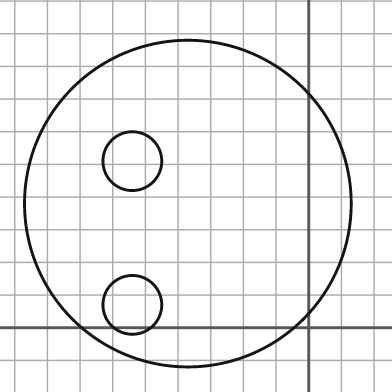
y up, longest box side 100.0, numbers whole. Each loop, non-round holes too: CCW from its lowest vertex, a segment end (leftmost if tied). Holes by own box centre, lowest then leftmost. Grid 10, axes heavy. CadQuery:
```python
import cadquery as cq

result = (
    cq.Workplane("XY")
    .moveTo(-37.0, 38.0)
    .circle(50.0)
    .moveTo(-54.0, 7.0)
    .circle(9.0)
    .moveTo(-54.0, 51.0)
    .circle(9.0)
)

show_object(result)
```